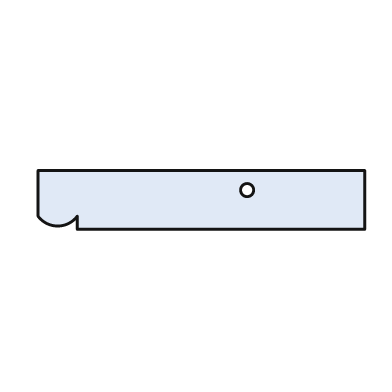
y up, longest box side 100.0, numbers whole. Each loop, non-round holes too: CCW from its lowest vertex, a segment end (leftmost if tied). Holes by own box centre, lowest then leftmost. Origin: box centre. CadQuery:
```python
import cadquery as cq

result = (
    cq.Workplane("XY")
    .moveTo(-38.0, -9.0)
    .lineTo(50.0, -9.0)
    .lineTo(50.0, 9.0)
    .lineTo(-50.0, 9.0)
    .lineTo(-50.0, -5.0)
    .threePointArc((-44.0, -8.0), (-38.0, -5.0))
    .close()
    .moveTo(14.0, 3.0)
    .circle(2.0)
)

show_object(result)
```